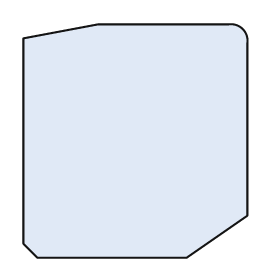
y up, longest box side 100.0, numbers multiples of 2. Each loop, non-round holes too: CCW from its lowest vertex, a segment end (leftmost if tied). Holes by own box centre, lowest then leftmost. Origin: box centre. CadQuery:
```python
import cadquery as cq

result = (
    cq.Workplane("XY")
    .moveTo(-42.0, -50.0)
    .lineTo(22.0, -50.0)
    .lineTo(48.0, -32.0)
    .lineTo(48.0, 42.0)
    .threePointArc((46.0, 48.0), (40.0, 50.0))
    .lineTo(-16.0, 50.0)
    .lineTo(-48.0, 44.0)
    .lineTo(-48.0, -44.0)
    .close()
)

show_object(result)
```